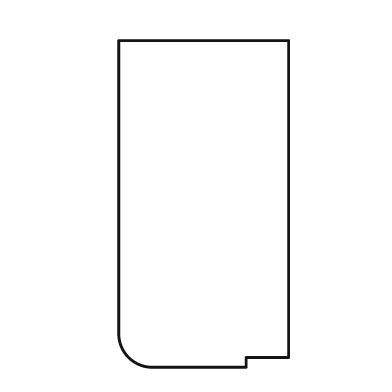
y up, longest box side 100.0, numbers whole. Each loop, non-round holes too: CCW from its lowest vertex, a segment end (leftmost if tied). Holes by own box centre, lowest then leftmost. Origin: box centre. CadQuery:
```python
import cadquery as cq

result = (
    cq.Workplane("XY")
    .moveTo(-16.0, -50.0)
    .lineTo(13.0, -50.0)
    .lineTo(13.0, -47.0)
    .lineTo(26.0, -47.0)
    .lineTo(26.0, 50.0)
    .lineTo(-26.0, 50.0)
    .lineTo(-26.0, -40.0)
    .threePointArc((-23.0, -47.0), (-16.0, -50.0))
    .close()
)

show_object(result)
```